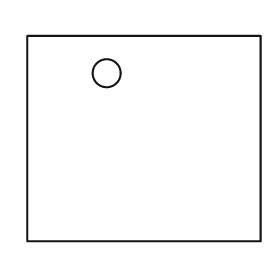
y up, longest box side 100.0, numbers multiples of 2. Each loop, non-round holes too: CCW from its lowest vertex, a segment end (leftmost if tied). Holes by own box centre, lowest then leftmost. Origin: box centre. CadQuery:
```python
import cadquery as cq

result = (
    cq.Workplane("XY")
    .moveTo(-50.0, -44.0)
    .lineTo(50.0, -44.0)
    .lineTo(50.0, 44.0)
    .lineTo(-50.0, 44.0)
    .close()
    .moveTo(-16.0, 28.0)
    .circle(6.0)
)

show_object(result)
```